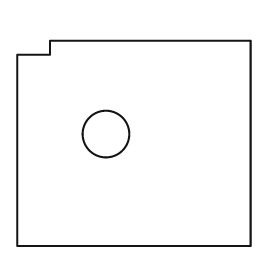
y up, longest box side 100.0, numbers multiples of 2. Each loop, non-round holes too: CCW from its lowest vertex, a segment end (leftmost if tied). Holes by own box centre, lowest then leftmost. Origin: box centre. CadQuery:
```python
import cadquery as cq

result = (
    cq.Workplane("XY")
    .moveTo(-50.0, -44.0)
    .lineTo(50.0, -44.0)
    .lineTo(50.0, 44.0)
    .lineTo(-36.0, 44.0)
    .lineTo(-36.0, 38.0)
    .lineTo(-50.0, 38.0)
    .close()
    .moveTo(-12.0, 4.0)
    .circle(10.0)
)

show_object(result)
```